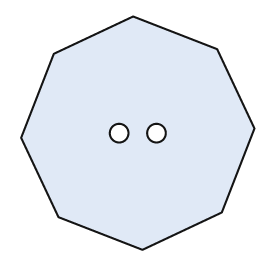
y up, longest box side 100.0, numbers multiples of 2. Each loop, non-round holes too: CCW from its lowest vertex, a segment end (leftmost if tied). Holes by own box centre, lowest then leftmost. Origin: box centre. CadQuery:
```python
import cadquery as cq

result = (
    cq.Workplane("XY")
    .moveTo(2.0, -50.0)
    .lineTo(36.0, -34.0)
    .lineTo(50.0, 2.0)
    .lineTo(34.0, 36.0)
    .lineTo(-2.0, 50.0)
    .lineTo(-36.0, 34.0)
    .lineTo(-50.0, -2.0)
    .lineTo(-34.0, -36.0)
    .close()
    .moveTo(-8.0, 0.0)
    .circle(4.0)
    .moveTo(8.0, 0.0)
    .circle(4.0)
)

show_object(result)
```